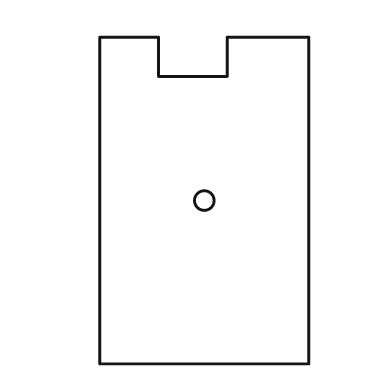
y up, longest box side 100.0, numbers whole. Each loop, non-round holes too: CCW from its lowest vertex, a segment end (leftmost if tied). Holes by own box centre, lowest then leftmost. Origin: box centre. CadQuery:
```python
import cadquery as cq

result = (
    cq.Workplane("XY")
    .moveTo(-32.0, -50.0)
    .lineTo(32.0, -50.0)
    .lineTo(32.0, 50.0)
    .lineTo(7.0, 50.0)
    .lineTo(7.0, 38.0)
    .lineTo(-14.0, 38.0)
    .lineTo(-14.0, 50.0)
    .lineTo(-32.0, 50.0)
    .close()
    .moveTo(0.0, 0.0)
    .circle(3.0)
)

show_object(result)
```